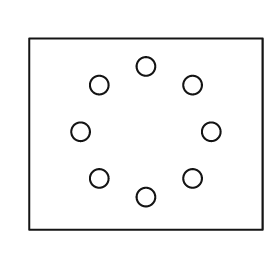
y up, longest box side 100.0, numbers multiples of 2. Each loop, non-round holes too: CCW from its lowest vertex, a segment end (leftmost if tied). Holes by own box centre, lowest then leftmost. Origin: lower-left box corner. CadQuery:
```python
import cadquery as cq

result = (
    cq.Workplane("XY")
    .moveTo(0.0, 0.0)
    .lineTo(100.0, 0.0)
    .lineTo(100.0, 82.0)
    .lineTo(0.0, 82.0)
    .close()
    .moveTo(50.0, 14.0)
    .circle(4.0)
    .moveTo(30.0, 22.0)
    .circle(4.0)
    .moveTo(70.0, 22.0)
    .circle(4.0)
    .moveTo(22.0, 42.0)
    .circle(4.0)
    .moveTo(78.0, 42.0)
    .circle(4.0)
    .moveTo(30.0, 62.0)
    .circle(4.0)
    .moveTo(70.0, 62.0)
    .circle(4.0)
    .moveTo(50.0, 70.0)
    .circle(4.0)
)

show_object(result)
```